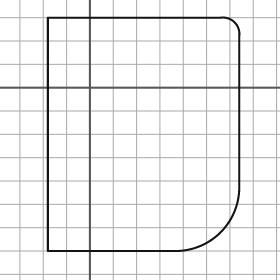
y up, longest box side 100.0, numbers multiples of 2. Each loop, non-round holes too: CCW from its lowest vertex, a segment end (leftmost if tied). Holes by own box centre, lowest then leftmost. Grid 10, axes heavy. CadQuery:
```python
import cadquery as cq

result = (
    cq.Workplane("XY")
    .moveTo(-18.0, -70.0)
    .lineTo(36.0, -70.0)
    .threePointArc((56.0, -62.0), (64.0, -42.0))
    .lineTo(64.0, 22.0)
    .threePointArc((62.0, 28.0), (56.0, 30.0))
    .lineTo(-18.0, 30.0)
    .close()
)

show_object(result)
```